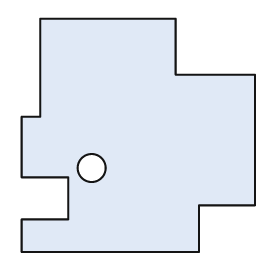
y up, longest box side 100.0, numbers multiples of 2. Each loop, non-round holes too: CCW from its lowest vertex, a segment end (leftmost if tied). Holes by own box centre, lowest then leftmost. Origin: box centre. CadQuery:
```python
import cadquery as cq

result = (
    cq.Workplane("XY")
    .moveTo(-50.0, -50.0)
    .lineTo(26.0, -50.0)
    .lineTo(26.0, -30.0)
    .lineTo(50.0, -30.0)
    .lineTo(50.0, 26.0)
    .lineTo(16.0, 26.0)
    .lineTo(16.0, 50.0)
    .lineTo(-42.0, 50.0)
    .lineTo(-42.0, 8.0)
    .lineTo(-50.0, 8.0)
    .lineTo(-50.0, -18.0)
    .lineTo(-30.0, -18.0)
    .lineTo(-30.0, -36.0)
    .lineTo(-50.0, -36.0)
    .close()
    .moveTo(-20.0, -14.0)
    .circle(6.0)
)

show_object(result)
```